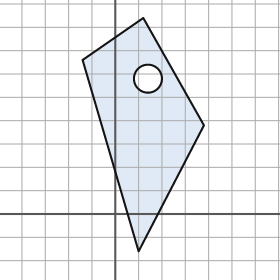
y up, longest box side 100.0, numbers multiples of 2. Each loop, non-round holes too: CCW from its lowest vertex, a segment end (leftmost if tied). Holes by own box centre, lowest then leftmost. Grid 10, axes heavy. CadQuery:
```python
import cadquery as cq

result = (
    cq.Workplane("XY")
    .moveTo(10.0, -16.0)
    .lineTo(38.0, 38.0)
    .lineTo(12.0, 84.0)
    .lineTo(-14.0, 66.0)
    .close()
    .moveTo(14.0, 58.0)
    .circle(6.0)
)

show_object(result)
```